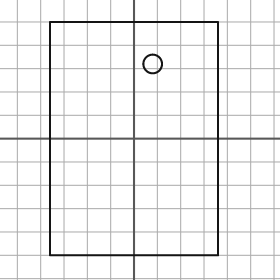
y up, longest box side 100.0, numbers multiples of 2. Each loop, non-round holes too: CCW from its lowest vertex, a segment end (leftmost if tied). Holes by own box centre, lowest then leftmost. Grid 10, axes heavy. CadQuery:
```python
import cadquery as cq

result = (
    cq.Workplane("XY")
    .moveTo(-36.0, -50.0)
    .lineTo(36.0, -50.0)
    .lineTo(36.0, 50.0)
    .lineTo(-36.0, 50.0)
    .close()
    .moveTo(8.0, 32.0)
    .circle(4.0)
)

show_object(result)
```